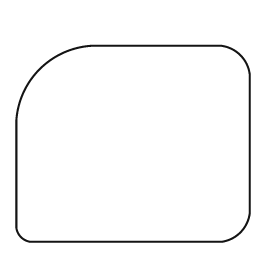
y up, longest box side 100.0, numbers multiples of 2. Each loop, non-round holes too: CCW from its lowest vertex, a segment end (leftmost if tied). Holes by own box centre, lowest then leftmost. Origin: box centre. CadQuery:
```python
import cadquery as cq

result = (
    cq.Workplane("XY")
    .moveTo(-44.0, -42.0)
    .lineTo(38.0, -42.0)
    .threePointArc((46.0, -38.0), (50.0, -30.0))
    .lineTo(50.0, 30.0)
    .threePointArc((46.0, 38.0), (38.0, 42.0))
    .lineTo(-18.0, 42.0)
    .threePointArc((-40.0, 32.0), (-50.0, 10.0))
    .lineTo(-50.0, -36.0)
    .threePointArc((-48.0, -40.0), (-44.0, -42.0))
    .close()
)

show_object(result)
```